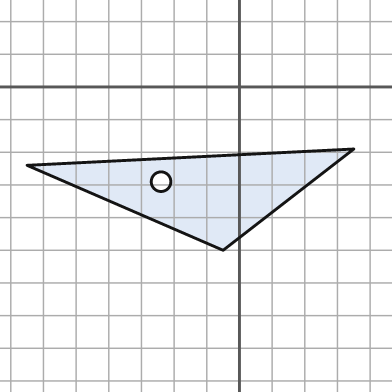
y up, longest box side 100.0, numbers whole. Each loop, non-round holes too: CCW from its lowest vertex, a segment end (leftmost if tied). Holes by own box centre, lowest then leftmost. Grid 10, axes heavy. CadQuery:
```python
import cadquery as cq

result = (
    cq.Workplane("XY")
    .moveTo(-5.0, -50.0)
    .lineTo(35.0, -19.0)
    .lineTo(-65.0, -24.0)
    .close()
    .moveTo(-24.0, -29.0)
    .circle(3.0)
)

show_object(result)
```